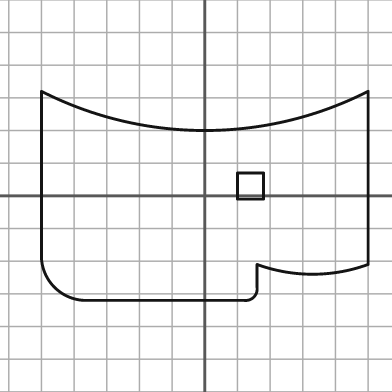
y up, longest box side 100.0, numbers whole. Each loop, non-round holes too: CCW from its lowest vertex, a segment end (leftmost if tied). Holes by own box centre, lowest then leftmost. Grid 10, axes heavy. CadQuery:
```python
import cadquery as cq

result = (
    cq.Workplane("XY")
    .moveTo(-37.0, -32.0)
    .lineTo(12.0, -32.0)
    .threePointArc((15.0, -31.0), (16.0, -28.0))
    .lineTo(16.0, -21.0)
    .threePointArc((33.0, -24.0), (50.0, -21.0))
    .lineTo(50.0, 32.0)
    .threePointArc((0.0, 20.0), (-50.0, 32.0))
    .lineTo(-50.0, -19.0)
    .threePointArc((-46.0, -28.0), (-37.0, -32.0))
    .close()
    .moveTo(10.0, -1.0)
    .lineTo(18.0, -1.0)
    .lineTo(18.0, 7.0)
    .lineTo(10.0, 7.0)
    .close()
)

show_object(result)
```